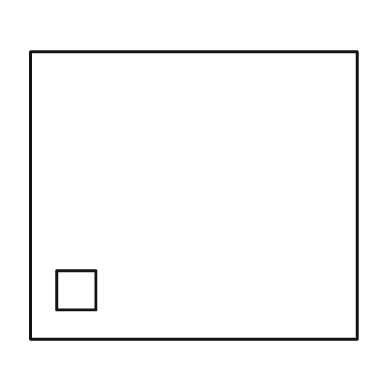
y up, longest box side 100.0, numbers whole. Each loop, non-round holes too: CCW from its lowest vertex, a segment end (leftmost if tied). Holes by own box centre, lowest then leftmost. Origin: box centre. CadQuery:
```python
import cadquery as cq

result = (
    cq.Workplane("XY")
    .moveTo(-50.0, -44.0)
    .lineTo(50.0, -44.0)
    .lineTo(50.0, 44.0)
    .lineTo(-50.0, 44.0)
    .close()
    .moveTo(-42.0, -35.0)
    .lineTo(-30.0, -35.0)
    .lineTo(-30.0, -23.0)
    .lineTo(-42.0, -23.0)
    .close()
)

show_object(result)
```